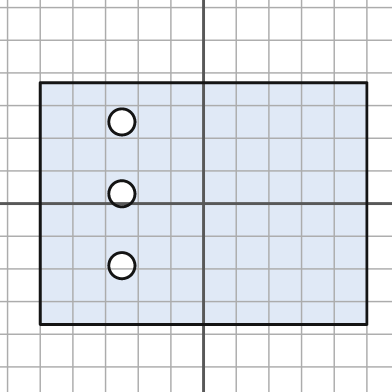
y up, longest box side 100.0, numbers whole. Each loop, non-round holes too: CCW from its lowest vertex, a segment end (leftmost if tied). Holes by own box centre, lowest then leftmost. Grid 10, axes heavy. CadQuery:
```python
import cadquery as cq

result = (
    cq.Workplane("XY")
    .moveTo(-50.0, -37.0)
    .lineTo(50.0, -37.0)
    .lineTo(50.0, 37.0)
    .lineTo(-50.0, 37.0)
    .close()
    .moveTo(-25.0, -19.0)
    .circle(4.0)
    .moveTo(-25.0, 3.0)
    .circle(4.0)
    .moveTo(-25.0, 25.0)
    .circle(4.0)
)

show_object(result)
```